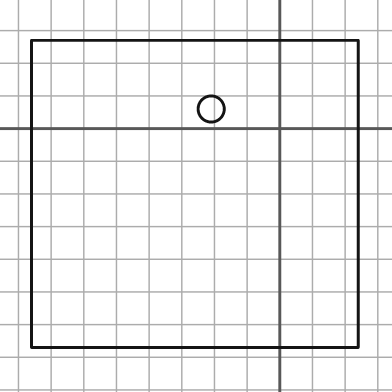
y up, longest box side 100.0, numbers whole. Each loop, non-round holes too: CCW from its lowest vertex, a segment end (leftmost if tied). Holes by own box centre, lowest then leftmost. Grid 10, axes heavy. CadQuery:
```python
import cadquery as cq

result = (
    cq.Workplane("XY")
    .moveTo(-76.0, -67.0)
    .lineTo(24.0, -67.0)
    .lineTo(24.0, 27.0)
    .lineTo(-76.0, 27.0)
    .close()
    .moveTo(-21.0, 6.0)
    .circle(4.0)
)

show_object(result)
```